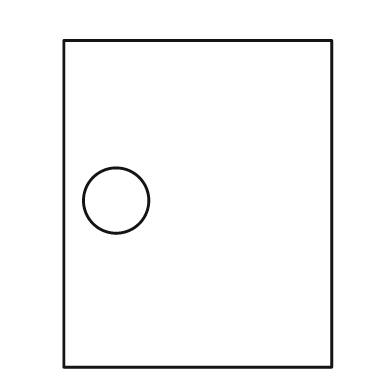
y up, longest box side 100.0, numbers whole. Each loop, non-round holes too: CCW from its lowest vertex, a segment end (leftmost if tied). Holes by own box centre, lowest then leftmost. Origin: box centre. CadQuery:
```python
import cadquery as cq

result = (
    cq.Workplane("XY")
    .moveTo(-41.0, -50.0)
    .lineTo(41.0, -50.0)
    .lineTo(41.0, 50.0)
    .lineTo(-41.0, 50.0)
    .close()
    .moveTo(-25.0, 1.0)
    .circle(10.0)
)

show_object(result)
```